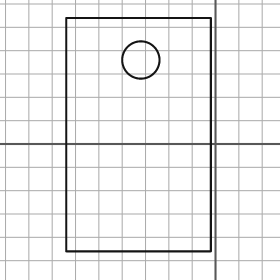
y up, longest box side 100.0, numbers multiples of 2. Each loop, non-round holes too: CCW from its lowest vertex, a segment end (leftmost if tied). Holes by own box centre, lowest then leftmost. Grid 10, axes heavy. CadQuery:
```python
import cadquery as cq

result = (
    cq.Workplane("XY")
    .moveTo(-64.0, -46.0)
    .lineTo(-2.0, -46.0)
    .lineTo(-2.0, 54.0)
    .lineTo(-64.0, 54.0)
    .close()
    .moveTo(-32.0, 36.0)
    .circle(8.0)
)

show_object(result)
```